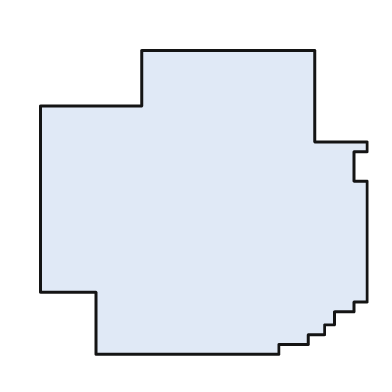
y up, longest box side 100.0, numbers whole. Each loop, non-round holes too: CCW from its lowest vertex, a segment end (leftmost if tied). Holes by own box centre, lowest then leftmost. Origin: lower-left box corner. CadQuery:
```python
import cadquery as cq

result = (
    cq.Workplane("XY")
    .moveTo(17.0, 0.0)
    .lineTo(73.0, 0.0)
    .lineTo(73.0, 3.0)
    .lineTo(82.0, 3.0)
    .lineTo(82.0, 6.0)
    .lineTo(87.0, 6.0)
    .lineTo(87.0, 9.0)
    .lineTo(90.0, 9.0)
    .lineTo(90.0, 13.0)
    .lineTo(96.0, 13.0)
    .lineTo(96.0, 16.0)
    .lineTo(100.0, 16.0)
    .lineTo(100.0, 53.0)
    .lineTo(96.0, 53.0)
    .lineTo(96.0, 62.0)
    .lineTo(100.0, 62.0)
    .lineTo(100.0, 65.0)
    .lineTo(84.0, 65.0)
    .lineTo(84.0, 93.0)
    .lineTo(31.0, 93.0)
    .lineTo(31.0, 76.0)
    .lineTo(0.0, 76.0)
    .lineTo(0.0, 19.0)
    .lineTo(17.0, 19.0)
    .close()
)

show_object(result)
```